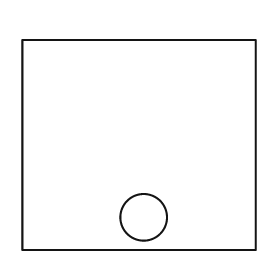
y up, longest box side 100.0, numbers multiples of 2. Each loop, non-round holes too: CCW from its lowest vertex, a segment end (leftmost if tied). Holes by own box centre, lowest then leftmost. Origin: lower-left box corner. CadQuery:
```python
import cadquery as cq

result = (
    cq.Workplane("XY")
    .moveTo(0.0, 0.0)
    .lineTo(100.0, 0.0)
    .lineTo(100.0, 90.0)
    .lineTo(0.0, 90.0)
    .close()
    .moveTo(52.0, 14.0)
    .circle(10.0)
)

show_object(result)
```